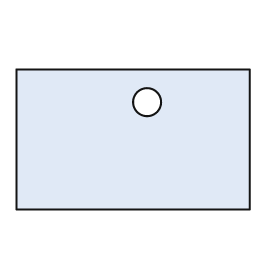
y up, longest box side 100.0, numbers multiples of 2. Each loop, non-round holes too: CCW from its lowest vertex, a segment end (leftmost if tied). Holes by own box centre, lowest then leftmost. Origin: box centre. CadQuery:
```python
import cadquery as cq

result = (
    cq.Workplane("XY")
    .moveTo(-50.0, -30.0)
    .lineTo(50.0, -30.0)
    .lineTo(50.0, 30.0)
    .lineTo(-50.0, 30.0)
    .close()
    .moveTo(6.0, 16.0)
    .circle(6.0)
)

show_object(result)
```